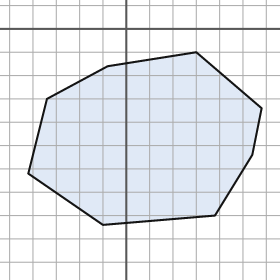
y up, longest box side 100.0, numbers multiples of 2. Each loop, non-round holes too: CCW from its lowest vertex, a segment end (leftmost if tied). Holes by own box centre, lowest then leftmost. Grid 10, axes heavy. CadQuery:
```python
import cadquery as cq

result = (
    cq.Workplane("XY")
    .moveTo(-10.0, -84.0)
    .lineTo(38.0, -80.0)
    .lineTo(54.0, -54.0)
    .lineTo(58.0, -34.0)
    .lineTo(30.0, -10.0)
    .lineTo(-8.0, -16.0)
    .lineTo(-34.0, -30.0)
    .lineTo(-42.0, -62.0)
    .close()
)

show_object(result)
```